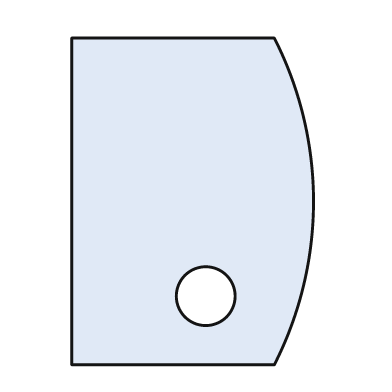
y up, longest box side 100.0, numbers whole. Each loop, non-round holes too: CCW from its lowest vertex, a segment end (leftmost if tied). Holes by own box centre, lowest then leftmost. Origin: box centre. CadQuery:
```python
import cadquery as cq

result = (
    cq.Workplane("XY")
    .moveTo(-37.0, -50.0)
    .lineTo(25.0, -50.0)
    .threePointArc((37.0, 0.0), (25.0, 50.0))
    .lineTo(-37.0, 50.0)
    .close()
    .moveTo(4.0, -29.0)
    .circle(9.0)
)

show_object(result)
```